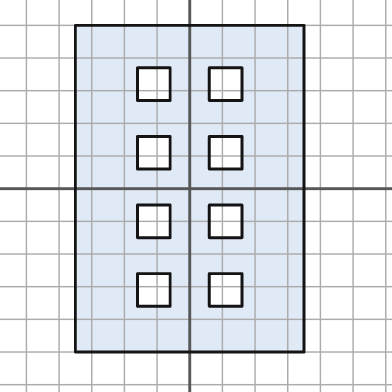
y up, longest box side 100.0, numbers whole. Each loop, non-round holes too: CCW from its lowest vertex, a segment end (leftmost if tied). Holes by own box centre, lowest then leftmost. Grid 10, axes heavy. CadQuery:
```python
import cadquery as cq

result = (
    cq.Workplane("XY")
    .moveTo(-35.0, -50.0)
    .lineTo(35.0, -50.0)
    .lineTo(35.0, 50.0)
    .lineTo(-35.0, 50.0)
    .close()
    .moveTo(-16.0, -36.0)
    .lineTo(-6.0, -36.0)
    .lineTo(-6.0, -26.0)
    .lineTo(-16.0, -26.0)
    .close()
    .moveTo(6.0, -36.0)
    .lineTo(16.0, -36.0)
    .lineTo(16.0, -26.0)
    .lineTo(6.0, -26.0)
    .close()
    .moveTo(-16.0, -15.0)
    .lineTo(-6.0, -15.0)
    .lineTo(-6.0, -5.0)
    .lineTo(-16.0, -5.0)
    .close()
    .moveTo(6.0, -15.0)
    .lineTo(16.0, -15.0)
    .lineTo(16.0, -5.0)
    .lineTo(6.0, -5.0)
    .close()
    .moveTo(-16.0, 6.0)
    .lineTo(-6.0, 6.0)
    .lineTo(-6.0, 16.0)
    .lineTo(-16.0, 16.0)
    .close()
    .moveTo(6.0, 6.0)
    .lineTo(16.0, 6.0)
    .lineTo(16.0, 16.0)
    .lineTo(6.0, 16.0)
    .close()
    .moveTo(-16.0, 27.0)
    .lineTo(-6.0, 27.0)
    .lineTo(-6.0, 37.0)
    .lineTo(-16.0, 37.0)
    .close()
    .moveTo(6.0, 27.0)
    .lineTo(16.0, 27.0)
    .lineTo(16.0, 37.0)
    .lineTo(6.0, 37.0)
    .close()
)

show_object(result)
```